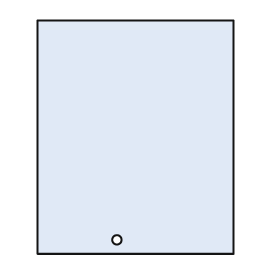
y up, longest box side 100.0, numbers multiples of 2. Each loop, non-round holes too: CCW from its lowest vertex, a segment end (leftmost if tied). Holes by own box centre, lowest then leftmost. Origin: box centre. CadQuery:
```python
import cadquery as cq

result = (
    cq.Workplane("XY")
    .moveTo(-42.0, -50.0)
    .lineTo(42.0, -50.0)
    .lineTo(42.0, 50.0)
    .lineTo(-42.0, 50.0)
    .close()
    .moveTo(-8.0, -44.0)
    .circle(2.0)
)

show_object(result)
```